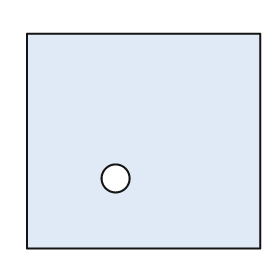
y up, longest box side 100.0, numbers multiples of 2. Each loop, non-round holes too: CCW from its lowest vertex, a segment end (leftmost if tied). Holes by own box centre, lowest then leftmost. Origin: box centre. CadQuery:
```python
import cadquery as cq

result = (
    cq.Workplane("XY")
    .moveTo(-50.0, -46.0)
    .lineTo(50.0, -46.0)
    .lineTo(50.0, 46.0)
    .lineTo(-50.0, 46.0)
    .close()
    .moveTo(-12.0, -16.0)
    .circle(6.0)
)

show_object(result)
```